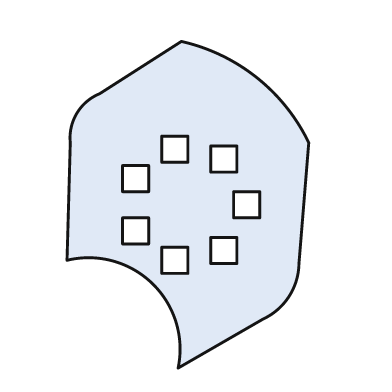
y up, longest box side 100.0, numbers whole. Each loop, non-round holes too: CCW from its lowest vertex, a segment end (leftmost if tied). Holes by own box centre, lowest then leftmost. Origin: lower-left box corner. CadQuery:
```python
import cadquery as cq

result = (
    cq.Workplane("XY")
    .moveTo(34.0, 0.0)
    .lineTo(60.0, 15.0)
    .threePointArc((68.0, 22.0), (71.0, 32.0))
    .lineTo(74.0, 69.0)
    .threePointArc((58.0, 89.0), (35.0, 100.0))
    .lineTo(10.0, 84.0)
    .threePointArc((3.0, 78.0), (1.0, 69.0))
    .lineTo(0.0, 33.0)
    .threePointArc((26.0, 26.0), (34.0, 0.0))
    .close()
    .moveTo(29.0, 29.0)
    .lineTo(37.0, 29.0)
    .lineTo(37.0, 37.0)
    .lineTo(29.0, 37.0)
    .close()
    .moveTo(44.0, 32.0)
    .lineTo(52.0, 32.0)
    .lineTo(52.0, 40.0)
    .lineTo(44.0, 40.0)
    .close()
    .moveTo(17.0, 38.0)
    .lineTo(25.0, 38.0)
    .lineTo(25.0, 46.0)
    .lineTo(17.0, 46.0)
    .close()
    .moveTo(51.0, 46.0)
    .lineTo(59.0, 46.0)
    .lineTo(59.0, 54.0)
    .lineTo(51.0, 54.0)
    .close()
    .moveTo(17.0, 54.0)
    .lineTo(25.0, 54.0)
    .lineTo(25.0, 62.0)
    .lineTo(17.0, 62.0)
    .close()
    .moveTo(44.0, 60.0)
    .lineTo(52.0, 60.0)
    .lineTo(52.0, 68.0)
    .lineTo(44.0, 68.0)
    .close()
    .moveTo(29.0, 63.0)
    .lineTo(37.0, 63.0)
    .lineTo(37.0, 71.0)
    .lineTo(29.0, 71.0)
    .close()
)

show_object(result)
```